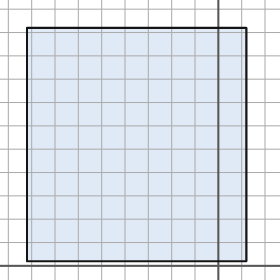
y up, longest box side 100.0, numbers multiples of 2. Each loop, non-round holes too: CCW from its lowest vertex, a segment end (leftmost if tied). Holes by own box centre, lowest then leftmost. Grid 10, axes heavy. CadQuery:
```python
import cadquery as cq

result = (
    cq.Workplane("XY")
    .moveTo(-82.0, 2.0)
    .lineTo(12.0, 2.0)
    .lineTo(12.0, 102.0)
    .lineTo(-82.0, 102.0)
    .close()
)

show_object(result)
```